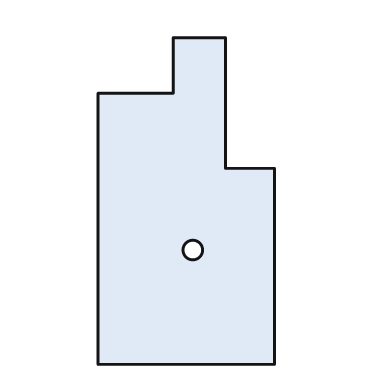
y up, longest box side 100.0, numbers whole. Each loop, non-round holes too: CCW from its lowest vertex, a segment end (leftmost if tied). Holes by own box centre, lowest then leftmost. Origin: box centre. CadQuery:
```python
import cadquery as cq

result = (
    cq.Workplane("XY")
    .moveTo(-27.0, -50.0)
    .lineTo(27.0, -50.0)
    .lineTo(27.0, 10.0)
    .lineTo(12.0, 10.0)
    .lineTo(12.0, 50.0)
    .lineTo(-4.0, 50.0)
    .lineTo(-4.0, 33.0)
    .lineTo(-27.0, 33.0)
    .close()
    .moveTo(2.0, -15.0)
    .circle(3.0)
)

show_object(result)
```